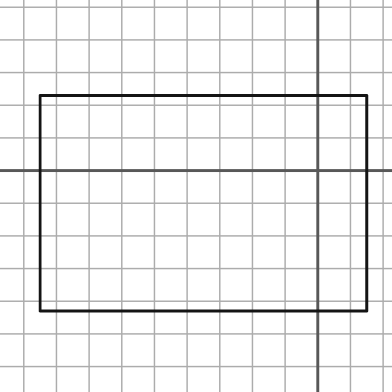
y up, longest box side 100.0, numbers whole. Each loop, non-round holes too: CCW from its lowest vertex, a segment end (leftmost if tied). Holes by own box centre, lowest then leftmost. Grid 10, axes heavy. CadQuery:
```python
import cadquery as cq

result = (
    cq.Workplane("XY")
    .moveTo(-85.0, -43.0)
    .lineTo(15.0, -43.0)
    .lineTo(15.0, 23.0)
    .lineTo(-85.0, 23.0)
    .close()
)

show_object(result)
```